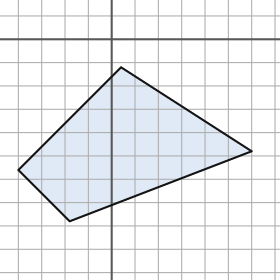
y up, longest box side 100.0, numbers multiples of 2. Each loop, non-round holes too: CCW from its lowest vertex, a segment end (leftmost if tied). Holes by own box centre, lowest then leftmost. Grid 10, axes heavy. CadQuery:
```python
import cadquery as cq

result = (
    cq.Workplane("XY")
    .moveTo(-18.0, -78.0)
    .lineTo(60.0, -48.0)
    .lineTo(4.0, -12.0)
    .lineTo(-40.0, -56.0)
    .close()
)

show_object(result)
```